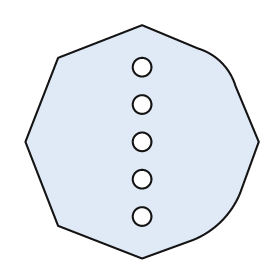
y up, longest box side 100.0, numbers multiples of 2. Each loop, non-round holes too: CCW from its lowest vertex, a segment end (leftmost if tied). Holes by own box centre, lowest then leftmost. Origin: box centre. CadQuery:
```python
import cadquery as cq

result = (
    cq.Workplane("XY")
    .moveTo(0.0, -50.0)
    .lineTo(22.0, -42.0)
    .threePointArc((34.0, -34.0), (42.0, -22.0))
    .lineTo(50.0, 0.0)
    .lineTo(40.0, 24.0)
    .threePointArc((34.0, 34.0), (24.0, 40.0))
    .lineTo(0.0, 50.0)
    .lineTo(-36.0, 36.0)
    .lineTo(-50.0, 0.0)
    .lineTo(-36.0, -36.0)
    .close()
    .moveTo(0.0, -32.0)
    .circle(4.0)
    .moveTo(0.0, -16.0)
    .circle(4.0)
    .moveTo(0.0, 0.0)
    .circle(4.0)
    .moveTo(0.0, 16.0)
    .circle(4.0)
    .moveTo(0.0, 32.0)
    .circle(4.0)
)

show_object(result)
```